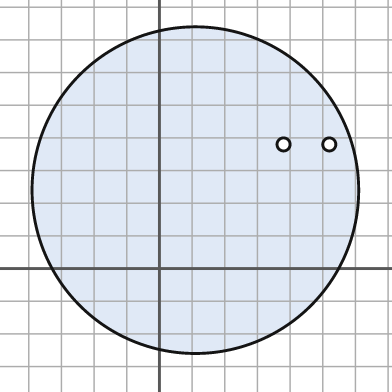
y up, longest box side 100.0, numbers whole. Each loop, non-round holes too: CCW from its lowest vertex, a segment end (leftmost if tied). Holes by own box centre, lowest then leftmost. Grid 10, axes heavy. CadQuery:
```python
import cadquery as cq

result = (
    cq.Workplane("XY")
    .moveTo(11.0, 24.0)
    .circle(50.0)
    .moveTo(38.0, 38.0)
    .circle(2.0)
    .moveTo(52.0, 38.0)
    .circle(2.0)
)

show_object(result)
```